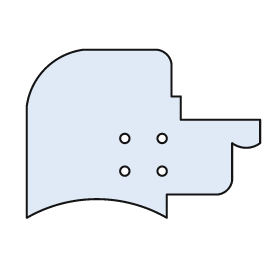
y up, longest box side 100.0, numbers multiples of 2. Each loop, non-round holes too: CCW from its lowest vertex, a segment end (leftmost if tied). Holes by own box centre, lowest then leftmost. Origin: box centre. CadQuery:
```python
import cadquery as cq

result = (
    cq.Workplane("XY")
    .moveTo(-50.0, -36.0)
    .threePointArc((-20.0, -28.0), (10.0, -36.0))
    .lineTo(10.0, -26.0)
    .lineTo(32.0, -26.0)
    .threePointArc((36.0, -24.0), (38.0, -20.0))
    .lineTo(38.0, -4.0)
    .threePointArc((44.0, -6.0), (50.0, -4.0))
    .lineTo(50.0, 6.0)
    .lineTo(16.0, 6.0)
    .lineTo(16.0, 16.0)
    .lineTo(12.0, 16.0)
    .lineTo(12.0, 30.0)
    .threePointArc((10.0, 34.0), (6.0, 36.0))
    .lineTo(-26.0, 36.0)
    .threePointArc((-42.0, 28.0), (-50.0, 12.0))
    .close()
    .moveTo(-8.0, -16.0)
    .circle(2.0)
    .moveTo(8.0, -16.0)
    .circle(2.0)
    .moveTo(-8.0, -2.0)
    .circle(2.0)
    .moveTo(8.0, -2.0)
    .circle(2.0)
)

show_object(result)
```